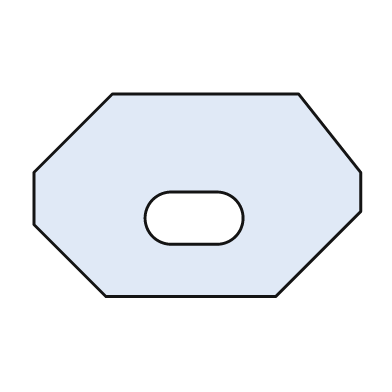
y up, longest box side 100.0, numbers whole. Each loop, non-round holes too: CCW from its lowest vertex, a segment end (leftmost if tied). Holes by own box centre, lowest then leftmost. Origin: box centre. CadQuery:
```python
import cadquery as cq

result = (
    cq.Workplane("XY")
    .moveTo(-28.0, -31.0)
    .lineTo(24.0, -31.0)
    .lineTo(50.0, -5.0)
    .lineTo(50.0, 7.0)
    .lineTo(31.0, 31.0)
    .lineTo(-26.0, 31.0)
    .lineTo(-50.0, 7.0)
    .lineTo(-50.0, -9.0)
    .close()
    .moveTo(-8.0, -15.0)
    .lineTo(6.0, -15.0)
    .threePointArc((14.0, -7.0), (6.0, 1.0))
    .lineTo(-8.0, 1.0)
    .threePointArc((-16.0, -7.0), (-8.0, -15.0))
    .close()
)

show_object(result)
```